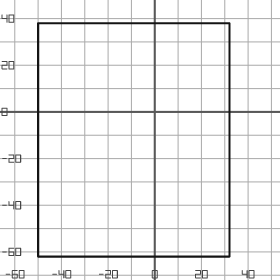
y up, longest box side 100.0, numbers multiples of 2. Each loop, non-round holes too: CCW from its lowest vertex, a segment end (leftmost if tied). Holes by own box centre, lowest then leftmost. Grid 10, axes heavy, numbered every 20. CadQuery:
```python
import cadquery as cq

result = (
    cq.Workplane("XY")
    .moveTo(-50.0, -62.0)
    .lineTo(32.0, -62.0)
    .lineTo(32.0, 38.0)
    .lineTo(-50.0, 38.0)
    .close()
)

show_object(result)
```